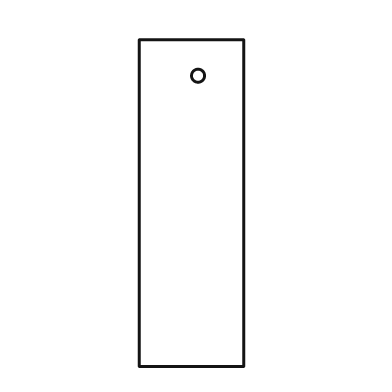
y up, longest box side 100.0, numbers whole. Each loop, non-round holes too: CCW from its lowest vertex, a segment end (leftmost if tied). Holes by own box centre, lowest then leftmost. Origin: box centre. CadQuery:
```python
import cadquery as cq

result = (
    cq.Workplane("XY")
    .moveTo(-16.0, -50.0)
    .lineTo(16.0, -50.0)
    .lineTo(16.0, 50.0)
    .lineTo(-16.0, 50.0)
    .close()
    .moveTo(2.0, 39.0)
    .circle(2.0)
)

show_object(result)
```